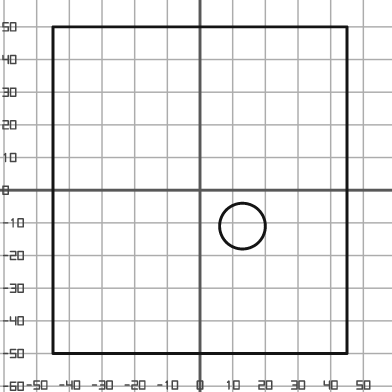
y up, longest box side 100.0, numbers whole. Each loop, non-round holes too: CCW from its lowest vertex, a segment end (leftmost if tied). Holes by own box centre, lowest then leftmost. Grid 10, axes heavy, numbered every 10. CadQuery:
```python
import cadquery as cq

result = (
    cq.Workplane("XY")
    .moveTo(-45.0, -50.0)
    .lineTo(45.0, -50.0)
    .lineTo(45.0, 50.0)
    .lineTo(-45.0, 50.0)
    .close()
    .moveTo(13.0, -11.0)
    .circle(7.0)
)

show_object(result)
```